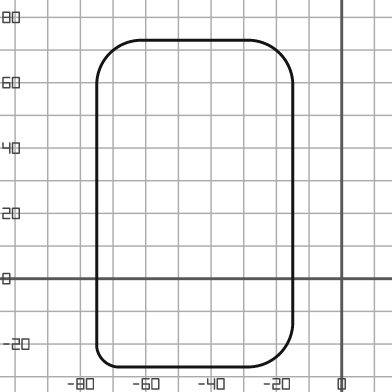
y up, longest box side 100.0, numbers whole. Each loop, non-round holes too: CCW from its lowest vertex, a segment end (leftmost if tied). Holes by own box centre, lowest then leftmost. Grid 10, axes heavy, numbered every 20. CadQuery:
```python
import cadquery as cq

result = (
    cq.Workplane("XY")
    .moveTo(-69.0, -27.0)
    .lineTo(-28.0, -27.0)
    .threePointArc((-19.0, -23.0), (-15.0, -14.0))
    .lineTo(-15.0, 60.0)
    .threePointArc((-19.0, 69.0), (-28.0, 73.0))
    .lineTo(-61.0, 73.0)
    .threePointArc((-71.0, 69.0), (-75.0, 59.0))
    .lineTo(-75.0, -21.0)
    .threePointArc((-73.0, -25.0), (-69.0, -27.0))
    .close()
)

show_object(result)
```